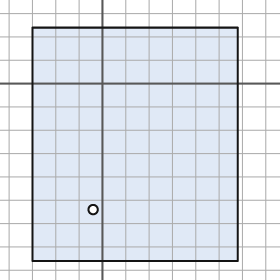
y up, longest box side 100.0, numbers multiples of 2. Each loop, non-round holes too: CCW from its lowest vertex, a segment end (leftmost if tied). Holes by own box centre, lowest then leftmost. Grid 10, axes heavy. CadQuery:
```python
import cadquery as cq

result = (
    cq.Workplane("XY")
    .moveTo(-30.0, -76.0)
    .lineTo(58.0, -76.0)
    .lineTo(58.0, 24.0)
    .lineTo(-30.0, 24.0)
    .close()
    .moveTo(-4.0, -54.0)
    .circle(2.0)
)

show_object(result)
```